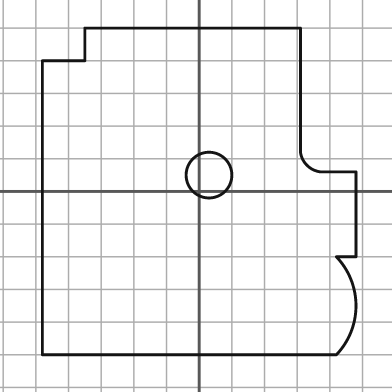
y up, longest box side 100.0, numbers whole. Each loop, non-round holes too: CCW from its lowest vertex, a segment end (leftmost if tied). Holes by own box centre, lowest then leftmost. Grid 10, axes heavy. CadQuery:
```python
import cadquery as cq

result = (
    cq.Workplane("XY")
    .moveTo(-48.0, -50.0)
    .lineTo(42.0, -50.0)
    .threePointArc((48.0, -35.0), (42.0, -20.0))
    .lineTo(48.0, -20.0)
    .lineTo(48.0, 6.0)
    .lineTo(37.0, 6.0)
    .threePointArc((33.0, 8.0), (31.0, 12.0))
    .lineTo(31.0, 50.0)
    .lineTo(-35.0, 50.0)
    .lineTo(-35.0, 40.0)
    .lineTo(-48.0, 40.0)
    .close()
    .moveTo(3.0, 5.0)
    .circle(7.0)
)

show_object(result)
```